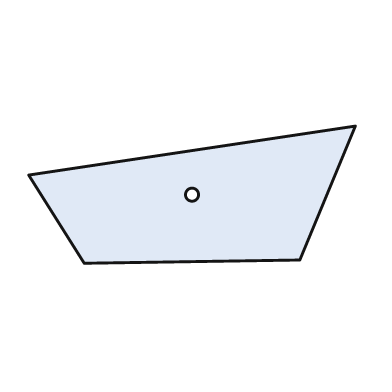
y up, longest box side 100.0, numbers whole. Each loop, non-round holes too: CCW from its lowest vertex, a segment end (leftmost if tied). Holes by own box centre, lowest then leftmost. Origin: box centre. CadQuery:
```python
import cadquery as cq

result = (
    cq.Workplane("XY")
    .moveTo(-33.0, -21.0)
    .lineTo(33.0, -20.0)
    .lineTo(50.0, 21.0)
    .lineTo(-50.0, 6.0)
    .close()
    .moveTo(0.0, 0.0)
    .circle(2.0)
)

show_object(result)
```